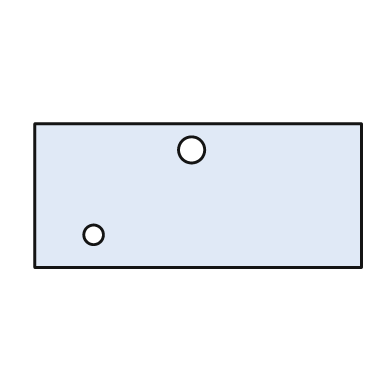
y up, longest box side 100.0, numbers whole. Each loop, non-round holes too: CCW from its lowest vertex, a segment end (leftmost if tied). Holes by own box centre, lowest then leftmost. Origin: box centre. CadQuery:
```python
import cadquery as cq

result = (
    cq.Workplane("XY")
    .moveTo(-50.0, -22.0)
    .lineTo(50.0, -22.0)
    .lineTo(50.0, 22.0)
    .lineTo(-50.0, 22.0)
    .close()
    .moveTo(-32.0, -12.0)
    .circle(3.0)
    .moveTo(-2.0, 14.0)
    .circle(4.0)
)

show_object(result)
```